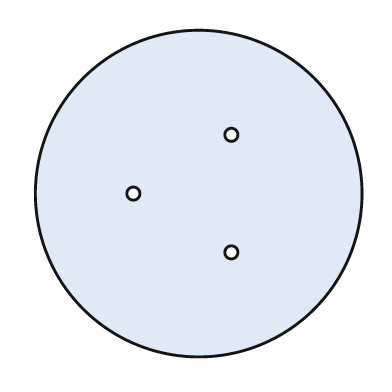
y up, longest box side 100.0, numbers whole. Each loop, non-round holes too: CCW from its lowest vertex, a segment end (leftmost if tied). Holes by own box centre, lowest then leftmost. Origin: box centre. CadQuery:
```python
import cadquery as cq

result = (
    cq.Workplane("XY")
    .moveTo(0.0, 0.0)
    .circle(50.0)
    .moveTo(10.0, -18.0)
    .circle(2.0)
    .moveTo(-20.0, 0.0)
    .circle(2.0)
    .moveTo(10.0, 18.0)
    .circle(2.0)
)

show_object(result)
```